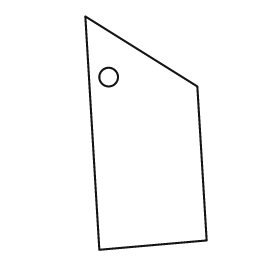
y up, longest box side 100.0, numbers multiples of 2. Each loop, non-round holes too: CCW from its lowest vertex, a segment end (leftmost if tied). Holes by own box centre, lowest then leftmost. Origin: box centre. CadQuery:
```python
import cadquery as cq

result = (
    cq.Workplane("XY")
    .moveTo(-20.0, -50.0)
    .lineTo(26.0, -46.0)
    .lineTo(22.0, 20.0)
    .lineTo(-26.0, 50.0)
    .close()
    .moveTo(-16.0, 24.0)
    .circle(4.0)
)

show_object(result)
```